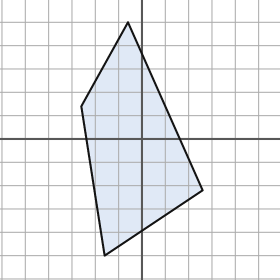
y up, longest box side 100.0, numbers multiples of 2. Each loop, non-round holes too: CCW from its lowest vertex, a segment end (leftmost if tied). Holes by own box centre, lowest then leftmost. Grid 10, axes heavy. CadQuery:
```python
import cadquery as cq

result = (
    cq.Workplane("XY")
    .moveTo(-16.0, -50.0)
    .lineTo(26.0, -22.0)
    .lineTo(-6.0, 50.0)
    .lineTo(-26.0, 14.0)
    .close()
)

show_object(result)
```